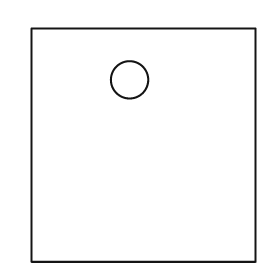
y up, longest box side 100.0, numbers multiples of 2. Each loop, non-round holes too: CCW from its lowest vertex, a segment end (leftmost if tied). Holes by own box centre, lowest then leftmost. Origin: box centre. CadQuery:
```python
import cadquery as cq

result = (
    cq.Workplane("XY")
    .moveTo(-48.0, -50.0)
    .lineTo(48.0, -50.0)
    .lineTo(48.0, 50.0)
    .lineTo(-48.0, 50.0)
    .close()
    .moveTo(-6.0, 28.0)
    .circle(8.0)
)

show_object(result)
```